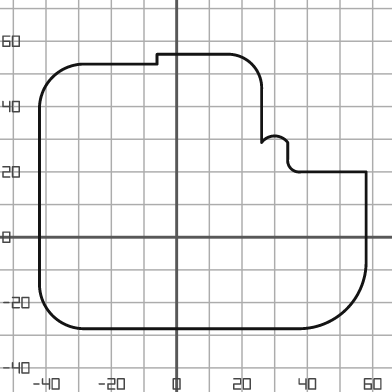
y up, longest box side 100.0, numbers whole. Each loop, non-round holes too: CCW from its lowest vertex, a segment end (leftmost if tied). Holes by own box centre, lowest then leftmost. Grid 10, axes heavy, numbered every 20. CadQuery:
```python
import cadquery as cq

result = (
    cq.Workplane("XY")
    .moveTo(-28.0, -28.0)
    .lineTo(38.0, -28.0)
    .threePointArc((52.0, -22.0), (58.0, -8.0))
    .lineTo(58.0, 20.0)
    .lineTo(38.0, 20.0)
    .threePointArc((35.0, 21.0), (34.0, 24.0))
    .lineTo(34.0, 29.0)
    .threePointArc((30.0, 31.0), (26.0, 29.0))
    .lineTo(26.0, 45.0)
    .threePointArc((23.0, 53.0), (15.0, 56.0))
    .lineTo(-6.0, 56.0)
    .lineTo(-6.0, 53.0)
    .lineTo(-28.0, 53.0)
    .threePointArc((-38.0, 49.0), (-42.0, 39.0))
    .lineTo(-42.0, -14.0)
    .threePointArc((-38.0, -24.0), (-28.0, -28.0))
    .close()
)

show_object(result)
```